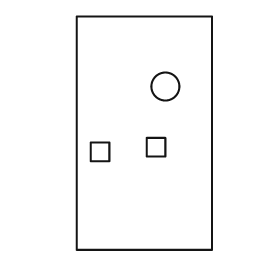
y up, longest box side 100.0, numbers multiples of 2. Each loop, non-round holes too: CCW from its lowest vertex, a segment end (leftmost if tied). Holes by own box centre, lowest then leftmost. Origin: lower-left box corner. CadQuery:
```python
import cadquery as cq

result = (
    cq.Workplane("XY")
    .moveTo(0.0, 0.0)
    .lineTo(58.0, 0.0)
    .lineTo(58.0, 100.0)
    .lineTo(0.0, 100.0)
    .close()
    .moveTo(6.0, 38.0)
    .lineTo(14.0, 38.0)
    .lineTo(14.0, 46.0)
    .lineTo(6.0, 46.0)
    .close()
    .moveTo(30.0, 40.0)
    .lineTo(38.0, 40.0)
    .lineTo(38.0, 48.0)
    .lineTo(30.0, 48.0)
    .close()
    .moveTo(38.0, 70.0)
    .circle(6.0)
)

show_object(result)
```